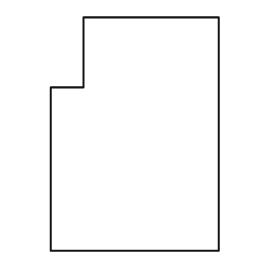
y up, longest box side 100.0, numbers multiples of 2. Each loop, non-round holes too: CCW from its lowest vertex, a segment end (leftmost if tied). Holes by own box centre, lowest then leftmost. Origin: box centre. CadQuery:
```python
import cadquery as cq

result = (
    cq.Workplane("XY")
    .moveTo(-36.0, -50.0)
    .lineTo(36.0, -50.0)
    .lineTo(36.0, 50.0)
    .lineTo(-22.0, 50.0)
    .lineTo(-22.0, 20.0)
    .lineTo(-36.0, 20.0)
    .close()
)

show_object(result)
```